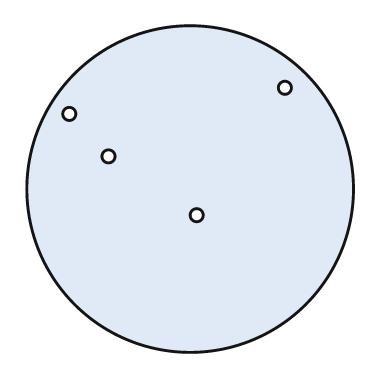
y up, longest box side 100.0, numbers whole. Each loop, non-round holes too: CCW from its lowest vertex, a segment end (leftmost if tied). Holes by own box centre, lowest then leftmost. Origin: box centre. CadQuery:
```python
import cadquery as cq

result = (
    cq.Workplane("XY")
    .moveTo(0.0, 0.0)
    .circle(50.0)
    .moveTo(2.0, -8.0)
    .circle(2.0)
    .moveTo(-25.0, 10.0)
    .circle(2.0)
    .moveTo(-37.0, 23.0)
    .circle(2.0)
    .moveTo(29.0, 31.0)
    .circle(2.0)
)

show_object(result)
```